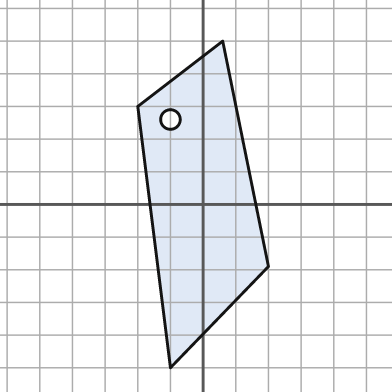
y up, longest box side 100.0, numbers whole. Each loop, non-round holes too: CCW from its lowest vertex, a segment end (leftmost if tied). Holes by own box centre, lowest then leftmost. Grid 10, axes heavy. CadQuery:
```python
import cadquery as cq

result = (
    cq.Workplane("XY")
    .moveTo(-10.0, -50.0)
    .lineTo(20.0, -19.0)
    .lineTo(6.0, 50.0)
    .lineTo(-20.0, 30.0)
    .close()
    .moveTo(-10.0, 26.0)
    .circle(3.0)
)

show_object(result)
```